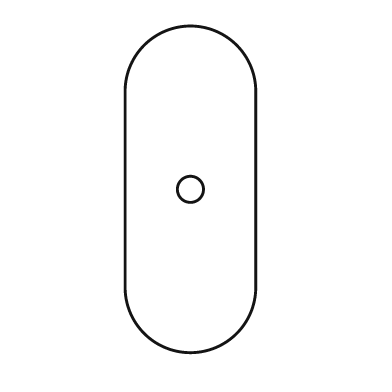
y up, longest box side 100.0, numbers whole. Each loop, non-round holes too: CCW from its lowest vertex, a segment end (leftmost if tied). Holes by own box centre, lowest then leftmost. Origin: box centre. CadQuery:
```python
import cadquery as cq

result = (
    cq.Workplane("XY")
    .moveTo(-20.0, -30.0)
    .threePointArc((0.0, -50.0), (20.0, -30.0))
    .lineTo(20.0, 30.0)
    .threePointArc((0.0, 50.0), (-20.0, 30.0))
    .close()
    .moveTo(0.0, 0.0)
    .circle(4.0)
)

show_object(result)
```